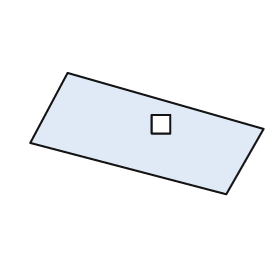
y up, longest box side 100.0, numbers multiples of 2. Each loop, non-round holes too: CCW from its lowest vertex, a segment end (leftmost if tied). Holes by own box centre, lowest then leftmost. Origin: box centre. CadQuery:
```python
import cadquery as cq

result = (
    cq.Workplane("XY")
    .moveTo(34.0, -26.0)
    .lineTo(50.0, 2.0)
    .lineTo(-34.0, 26.0)
    .lineTo(-50.0, -4.0)
    .close()
    .moveTo(2.0, 0.0)
    .lineTo(10.0, 0.0)
    .lineTo(10.0, 8.0)
    .lineTo(2.0, 8.0)
    .close()
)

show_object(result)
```